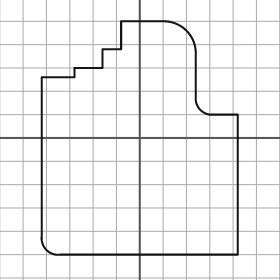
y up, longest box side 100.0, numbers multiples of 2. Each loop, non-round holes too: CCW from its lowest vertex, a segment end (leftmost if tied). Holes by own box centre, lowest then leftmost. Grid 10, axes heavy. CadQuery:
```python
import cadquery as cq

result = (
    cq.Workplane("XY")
    .moveTo(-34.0, -50.0)
    .lineTo(42.0, -50.0)
    .lineTo(42.0, 10.0)
    .lineTo(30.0, 10.0)
    .threePointArc((26.0, 12.0), (24.0, 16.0))
    .lineTo(24.0, 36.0)
    .threePointArc((20.0, 46.0), (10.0, 50.0))
    .lineTo(-8.0, 50.0)
    .lineTo(-8.0, 38.0)
    .lineTo(-16.0, 38.0)
    .lineTo(-16.0, 30.0)
    .lineTo(-28.0, 30.0)
    .lineTo(-28.0, 26.0)
    .lineTo(-42.0, 26.0)
    .lineTo(-42.0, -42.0)
    .threePointArc((-40.0, -48.0), (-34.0, -50.0))
    .close()
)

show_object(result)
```